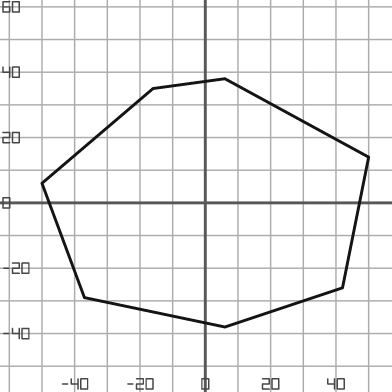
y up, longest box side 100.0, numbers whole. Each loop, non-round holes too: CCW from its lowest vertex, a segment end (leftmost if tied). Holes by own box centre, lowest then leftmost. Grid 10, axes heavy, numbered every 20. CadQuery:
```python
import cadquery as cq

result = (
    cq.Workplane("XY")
    .moveTo(6.0, -38.0)
    .lineTo(42.0, -26.0)
    .lineTo(50.0, 14.0)
    .lineTo(6.0, 38.0)
    .lineTo(-16.0, 35.0)
    .lineTo(-50.0, 6.0)
    .lineTo(-37.0, -29.0)
    .close()
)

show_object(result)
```